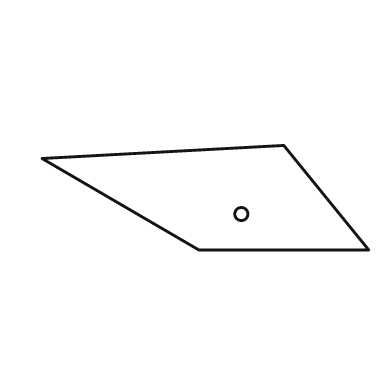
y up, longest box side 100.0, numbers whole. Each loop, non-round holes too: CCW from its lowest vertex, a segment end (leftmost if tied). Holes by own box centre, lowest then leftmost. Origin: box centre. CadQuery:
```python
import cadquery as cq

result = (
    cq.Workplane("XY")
    .moveTo(-2.0, -16.0)
    .lineTo(50.0, -16.0)
    .lineTo(24.0, 16.0)
    .lineTo(-50.0, 12.0)
    .close()
    .moveTo(11.0, -5.0)
    .circle(2.0)
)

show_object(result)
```